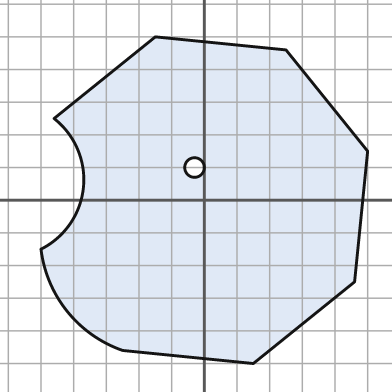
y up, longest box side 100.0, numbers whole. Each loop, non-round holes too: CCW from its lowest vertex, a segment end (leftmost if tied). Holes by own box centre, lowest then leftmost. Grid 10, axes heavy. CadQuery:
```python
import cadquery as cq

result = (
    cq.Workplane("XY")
    .moveTo(15.0, -50.0)
    .lineTo(46.0, -25.0)
    .lineTo(50.0, 15.0)
    .lineTo(25.0, 46.0)
    .lineTo(-15.0, 50.0)
    .lineTo(-46.0, 25.0)
    .threePointArc((-37.0, 4.0), (-50.0, -15.0))
    .threePointArc((-42.0, -34.0), (-25.0, -46.0))
    .close()
    .moveTo(-3.0, 10.0)
    .circle(3.0)
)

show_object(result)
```